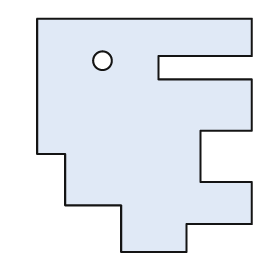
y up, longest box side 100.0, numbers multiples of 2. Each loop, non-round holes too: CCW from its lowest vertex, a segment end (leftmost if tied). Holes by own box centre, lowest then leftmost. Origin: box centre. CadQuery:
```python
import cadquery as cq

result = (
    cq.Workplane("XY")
    .moveTo(-10.0, -50.0)
    .lineTo(18.0, -50.0)
    .lineTo(18.0, -38.0)
    .lineTo(46.0, -38.0)
    .lineTo(46.0, -20.0)
    .lineTo(24.0, -20.0)
    .lineTo(24.0, 2.0)
    .lineTo(46.0, 2.0)
    .lineTo(46.0, 24.0)
    .lineTo(6.0, 24.0)
    .lineTo(6.0, 34.0)
    .lineTo(46.0, 34.0)
    .lineTo(46.0, 50.0)
    .lineTo(-46.0, 50.0)
    .lineTo(-46.0, -8.0)
    .lineTo(-34.0, -8.0)
    .lineTo(-34.0, -30.0)
    .lineTo(-10.0, -30.0)
    .close()
    .moveTo(-18.0, 32.0)
    .circle(4.0)
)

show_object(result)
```